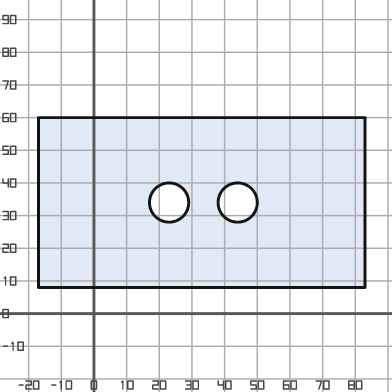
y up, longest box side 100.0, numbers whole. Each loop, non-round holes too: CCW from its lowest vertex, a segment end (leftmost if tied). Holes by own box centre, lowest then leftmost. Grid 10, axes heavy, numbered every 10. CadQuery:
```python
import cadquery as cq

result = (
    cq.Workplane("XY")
    .moveTo(-17.0, 8.0)
    .lineTo(83.0, 8.0)
    .lineTo(83.0, 60.0)
    .lineTo(-17.0, 60.0)
    .close()
    .moveTo(23.0, 34.0)
    .circle(6.0)
    .moveTo(44.0, 34.0)
    .circle(6.0)
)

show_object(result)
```